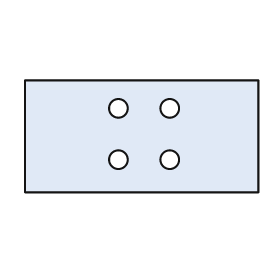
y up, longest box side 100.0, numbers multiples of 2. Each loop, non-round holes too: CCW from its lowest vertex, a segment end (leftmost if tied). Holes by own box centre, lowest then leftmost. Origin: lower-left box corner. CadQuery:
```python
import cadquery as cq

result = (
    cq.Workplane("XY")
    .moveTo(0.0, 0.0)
    .lineTo(100.0, 0.0)
    .lineTo(100.0, 48.0)
    .lineTo(0.0, 48.0)
    .close()
    .moveTo(40.0, 14.0)
    .circle(4.0)
    .moveTo(62.0, 14.0)
    .circle(4.0)
    .moveTo(40.0, 36.0)
    .circle(4.0)
    .moveTo(62.0, 36.0)
    .circle(4.0)
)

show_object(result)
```